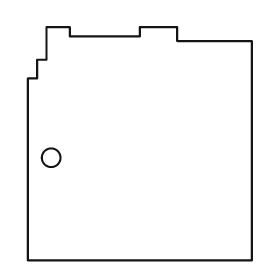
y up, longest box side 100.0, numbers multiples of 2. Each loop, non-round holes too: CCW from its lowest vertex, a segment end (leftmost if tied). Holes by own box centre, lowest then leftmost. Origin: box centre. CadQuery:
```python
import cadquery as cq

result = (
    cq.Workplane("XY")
    .moveTo(-48.0, -50.0)
    .lineTo(48.0, -50.0)
    .lineTo(48.0, 44.0)
    .lineTo(16.0, 44.0)
    .lineTo(16.0, 50.0)
    .lineTo(0.0, 50.0)
    .lineTo(0.0, 46.0)
    .lineTo(-30.0, 46.0)
    .lineTo(-30.0, 50.0)
    .lineTo(-40.0, 50.0)
    .lineTo(-40.0, 36.0)
    .lineTo(-44.0, 36.0)
    .lineTo(-44.0, 28.0)
    .lineTo(-48.0, 28.0)
    .close()
    .moveTo(-38.0, -6.0)
    .circle(4.0)
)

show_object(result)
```